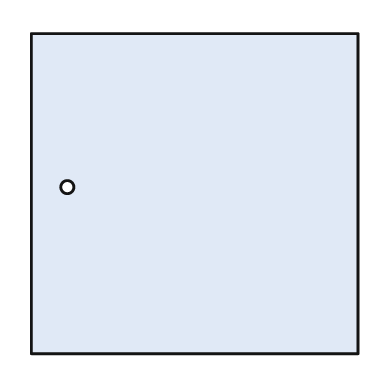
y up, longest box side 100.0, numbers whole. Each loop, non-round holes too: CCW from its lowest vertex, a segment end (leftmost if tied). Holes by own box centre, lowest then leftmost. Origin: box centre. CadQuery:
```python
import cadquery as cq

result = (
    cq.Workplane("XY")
    .moveTo(-50.0, -49.0)
    .lineTo(50.0, -49.0)
    .lineTo(50.0, 49.0)
    .lineTo(-50.0, 49.0)
    .close()
    .moveTo(-39.0, 2.0)
    .circle(2.0)
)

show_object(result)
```